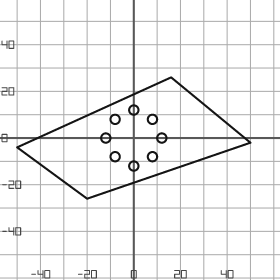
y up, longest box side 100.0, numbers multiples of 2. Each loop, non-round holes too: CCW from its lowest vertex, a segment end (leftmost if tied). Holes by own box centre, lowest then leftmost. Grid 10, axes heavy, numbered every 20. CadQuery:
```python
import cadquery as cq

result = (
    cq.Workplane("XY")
    .moveTo(-20.0, -26.0)
    .lineTo(50.0, -2.0)
    .lineTo(16.0, 26.0)
    .lineTo(-50.0, -4.0)
    .close()
    .moveTo(0.0, -12.0)
    .circle(2.0)
    .moveTo(-8.0, -8.0)
    .circle(2.0)
    .moveTo(8.0, -8.0)
    .circle(2.0)
    .moveTo(-12.0, 0.0)
    .circle(2.0)
    .moveTo(12.0, 0.0)
    .circle(2.0)
    .moveTo(-8.0, 8.0)
    .circle(2.0)
    .moveTo(8.0, 8.0)
    .circle(2.0)
    .moveTo(0.0, 12.0)
    .circle(2.0)
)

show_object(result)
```